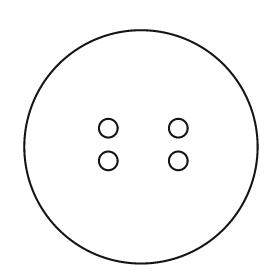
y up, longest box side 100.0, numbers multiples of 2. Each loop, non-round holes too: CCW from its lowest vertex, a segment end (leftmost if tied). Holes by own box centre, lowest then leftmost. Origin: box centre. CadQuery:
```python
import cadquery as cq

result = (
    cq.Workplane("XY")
    .moveTo(0.0, 0.0)
    .circle(50.0)
    .moveTo(-14.0, -6.0)
    .circle(4.0)
    .moveTo(16.0, -6.0)
    .circle(4.0)
    .moveTo(-14.0, 8.0)
    .circle(4.0)
    .moveTo(16.0, 8.0)
    .circle(4.0)
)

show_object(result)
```